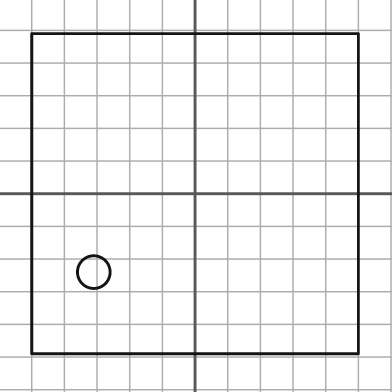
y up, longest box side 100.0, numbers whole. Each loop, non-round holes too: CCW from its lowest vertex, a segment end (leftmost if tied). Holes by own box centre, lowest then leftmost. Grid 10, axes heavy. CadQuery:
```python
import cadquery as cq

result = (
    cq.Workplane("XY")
    .moveTo(-50.0, -49.0)
    .lineTo(50.0, -49.0)
    .lineTo(50.0, 49.0)
    .lineTo(-50.0, 49.0)
    .close()
    .moveTo(-31.0, -24.0)
    .circle(5.0)
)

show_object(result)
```